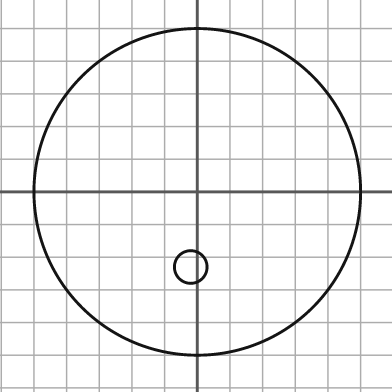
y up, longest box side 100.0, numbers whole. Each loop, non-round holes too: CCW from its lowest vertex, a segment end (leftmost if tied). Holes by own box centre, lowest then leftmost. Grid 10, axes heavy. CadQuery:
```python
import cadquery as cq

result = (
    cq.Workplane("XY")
    .moveTo(0.0, 0.0)
    .circle(50.0)
    .moveTo(-2.0, -23.0)
    .circle(5.0)
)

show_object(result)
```